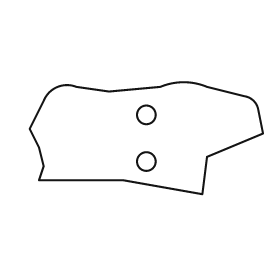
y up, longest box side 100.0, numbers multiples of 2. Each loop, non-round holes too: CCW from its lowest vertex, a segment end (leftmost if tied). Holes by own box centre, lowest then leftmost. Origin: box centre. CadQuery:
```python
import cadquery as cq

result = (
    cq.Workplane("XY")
    .moveTo(24.0, -24.0)
    .lineTo(26.0, -8.0)
    .lineTo(50.0, 2.0)
    .lineTo(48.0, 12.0)
    .threePointArc((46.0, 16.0), (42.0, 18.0))
    .lineTo(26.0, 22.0)
    .threePointArc((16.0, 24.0), (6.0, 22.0))
    .lineTo(-16.0, 20.0)
    .lineTo(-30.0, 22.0)
    .threePointArc((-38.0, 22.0), (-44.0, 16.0))
    .lineTo(-50.0, 4.0)
    .lineTo(-46.0, -4.0)
    .lineTo(-44.0, -12.0)
    .lineTo(-46.0, -18.0)
    .lineTo(-10.0, -18.0)
    .close()
    .moveTo(0.0, -10.0)
    .circle(4.0)
    .moveTo(0.0, 10.0)
    .circle(4.0)
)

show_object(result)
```